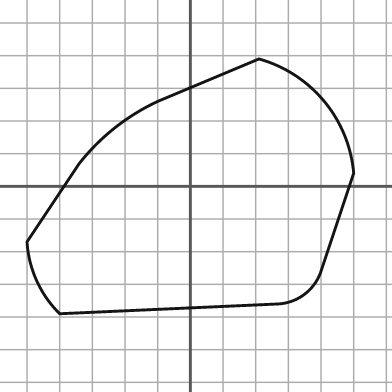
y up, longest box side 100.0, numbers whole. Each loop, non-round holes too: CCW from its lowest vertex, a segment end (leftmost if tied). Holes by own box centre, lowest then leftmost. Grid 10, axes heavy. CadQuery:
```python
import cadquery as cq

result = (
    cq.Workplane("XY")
    .moveTo(-40.0, -39.0)
    .lineTo(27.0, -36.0)
    .threePointArc((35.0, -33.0), (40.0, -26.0))
    .lineTo(50.0, 4.0)
    .threePointArc((41.0, 26.0), (21.0, 39.0))
    .lineTo(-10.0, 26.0)
    .threePointArc((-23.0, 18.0), (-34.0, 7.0))
    .lineTo(-50.0, -17.0)
    .threePointArc((-47.0, -29.0), (-40.0, -39.0))
    .close()
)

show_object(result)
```